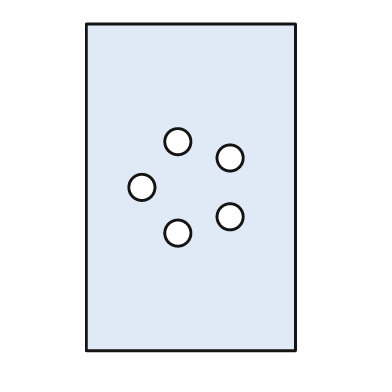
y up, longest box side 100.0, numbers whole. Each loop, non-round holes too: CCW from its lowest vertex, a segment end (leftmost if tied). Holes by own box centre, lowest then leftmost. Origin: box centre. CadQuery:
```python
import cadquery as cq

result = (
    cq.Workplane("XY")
    .moveTo(-32.0, -50.0)
    .lineTo(32.0, -50.0)
    .lineTo(32.0, 50.0)
    .lineTo(-32.0, 50.0)
    .close()
    .moveTo(-4.0, -14.0)
    .circle(4.0)
    .moveTo(12.0, -9.0)
    .circle(4.0)
    .moveTo(-15.0, 0.0)
    .circle(4.0)
    .moveTo(12.0, 9.0)
    .circle(4.0)
    .moveTo(-4.0, 14.0)
    .circle(4.0)
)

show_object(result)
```